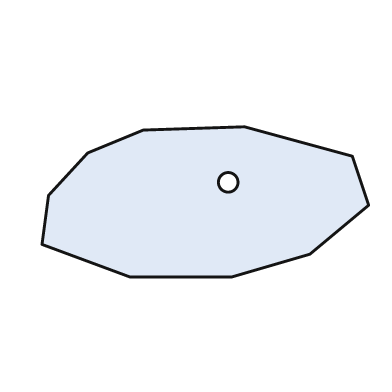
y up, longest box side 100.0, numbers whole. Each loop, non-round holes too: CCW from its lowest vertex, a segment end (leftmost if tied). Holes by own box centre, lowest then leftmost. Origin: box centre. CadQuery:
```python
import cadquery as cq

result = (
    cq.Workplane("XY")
    .moveTo(-23.0, -23.0)
    .lineTo(8.0, -23.0)
    .lineTo(32.0, -16.0)
    .lineTo(50.0, -1.0)
    .lineTo(45.0, 14.0)
    .lineTo(12.0, 23.0)
    .lineTo(-19.0, 22.0)
    .lineTo(-36.0, 15.0)
    .lineTo(-48.0, 2.0)
    .lineTo(-50.0, -13.0)
    .close()
    .moveTo(7.0, 6.0)
    .circle(3.0)
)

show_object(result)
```